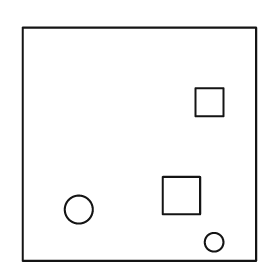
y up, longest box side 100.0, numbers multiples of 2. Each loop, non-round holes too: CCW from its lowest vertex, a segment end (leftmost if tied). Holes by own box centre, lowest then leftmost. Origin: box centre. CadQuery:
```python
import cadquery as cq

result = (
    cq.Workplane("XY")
    .moveTo(-50.0, -50.0)
    .lineTo(50.0, -50.0)
    .lineTo(50.0, 50.0)
    .lineTo(-50.0, 50.0)
    .close()
    .moveTo(32.0, -42.0)
    .circle(4.0)
    .moveTo(-26.0, -28.0)
    .circle(6.0)
    .moveTo(10.0, -30.0)
    .lineTo(26.0, -30.0)
    .lineTo(26.0, -14.0)
    .lineTo(10.0, -14.0)
    .close()
    .moveTo(24.0, 12.0)
    .lineTo(36.0, 12.0)
    .lineTo(36.0, 24.0)
    .lineTo(24.0, 24.0)
    .close()
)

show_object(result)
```